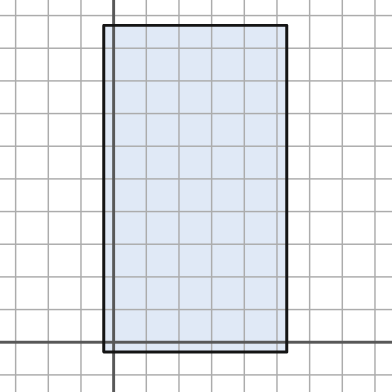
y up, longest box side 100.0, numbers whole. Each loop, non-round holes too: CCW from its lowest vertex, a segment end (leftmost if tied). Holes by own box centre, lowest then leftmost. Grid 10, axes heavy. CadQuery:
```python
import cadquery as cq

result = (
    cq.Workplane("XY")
    .moveTo(-3.0, -3.0)
    .lineTo(53.0, -3.0)
    .lineTo(53.0, 97.0)
    .lineTo(-3.0, 97.0)
    .close()
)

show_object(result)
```